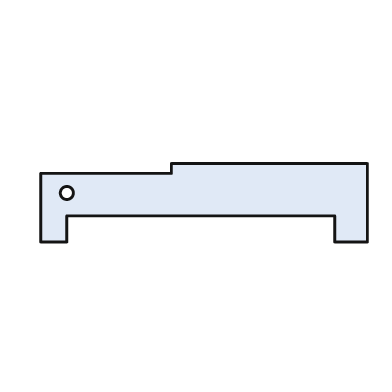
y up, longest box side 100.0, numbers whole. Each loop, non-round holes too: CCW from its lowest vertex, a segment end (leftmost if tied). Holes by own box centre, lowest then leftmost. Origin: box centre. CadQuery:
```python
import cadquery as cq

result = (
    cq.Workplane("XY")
    .moveTo(-50.0, -12.0)
    .lineTo(-42.0, -12.0)
    .lineTo(-42.0, -4.0)
    .lineTo(40.0, -4.0)
    .lineTo(40.0, -12.0)
    .lineTo(50.0, -12.0)
    .lineTo(50.0, 12.0)
    .lineTo(-10.0, 12.0)
    .lineTo(-10.0, 9.0)
    .lineTo(-50.0, 9.0)
    .close()
    .moveTo(-42.0, 3.0)
    .circle(2.0)
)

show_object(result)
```